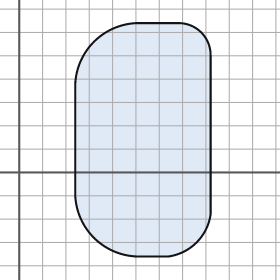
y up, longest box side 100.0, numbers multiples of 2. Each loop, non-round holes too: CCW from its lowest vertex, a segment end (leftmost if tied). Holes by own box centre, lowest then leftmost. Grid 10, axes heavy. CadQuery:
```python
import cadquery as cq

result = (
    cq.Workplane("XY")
    .moveTo(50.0, -36.0)
    .lineTo(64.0, -36.0)
    .threePointArc((76.0, -30.0), (82.0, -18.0))
    .lineTo(82.0, 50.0)
    .threePointArc((78.0, 60.0), (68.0, 64.0))
    .lineTo(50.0, 64.0)
    .threePointArc((32.0, 56.0), (24.0, 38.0))
    .lineTo(24.0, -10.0)
    .threePointArc((32.0, -28.0), (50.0, -36.0))
    .close()
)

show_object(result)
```